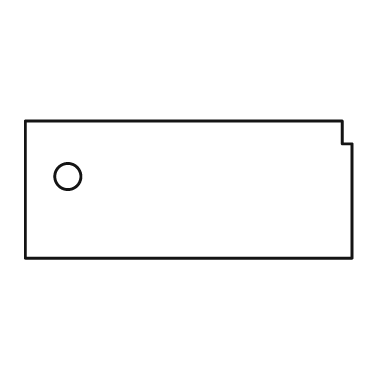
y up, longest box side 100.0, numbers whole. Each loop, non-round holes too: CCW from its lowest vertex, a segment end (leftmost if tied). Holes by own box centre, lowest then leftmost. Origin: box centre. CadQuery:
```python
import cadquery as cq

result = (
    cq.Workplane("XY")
    .moveTo(-50.0, -21.0)
    .lineTo(50.0, -21.0)
    .lineTo(50.0, 14.0)
    .lineTo(47.0, 14.0)
    .lineTo(47.0, 21.0)
    .lineTo(-50.0, 21.0)
    .close()
    .moveTo(-37.0, 4.0)
    .circle(4.0)
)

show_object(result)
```